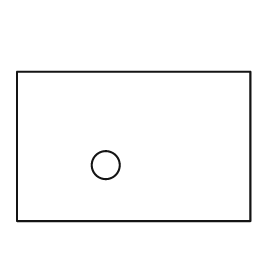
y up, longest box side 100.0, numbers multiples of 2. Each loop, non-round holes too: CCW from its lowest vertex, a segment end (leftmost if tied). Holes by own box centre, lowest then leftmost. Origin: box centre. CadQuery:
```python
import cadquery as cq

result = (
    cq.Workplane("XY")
    .moveTo(-50.0, -32.0)
    .lineTo(50.0, -32.0)
    .lineTo(50.0, 32.0)
    .lineTo(-50.0, 32.0)
    .close()
    .moveTo(-12.0, -8.0)
    .circle(6.0)
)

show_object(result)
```